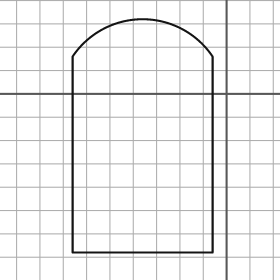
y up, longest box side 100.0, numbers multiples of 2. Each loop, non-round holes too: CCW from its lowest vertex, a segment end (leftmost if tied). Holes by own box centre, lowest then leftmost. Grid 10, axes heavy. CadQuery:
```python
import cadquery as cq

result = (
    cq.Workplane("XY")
    .moveTo(-66.0, -68.0)
    .lineTo(-6.0, -68.0)
    .lineTo(-6.0, 16.0)
    .threePointArc((-36.0, 32.0), (-66.0, 16.0))
    .close()
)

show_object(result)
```